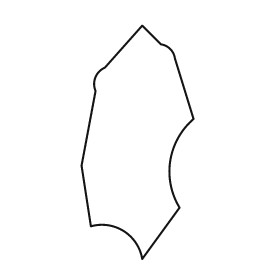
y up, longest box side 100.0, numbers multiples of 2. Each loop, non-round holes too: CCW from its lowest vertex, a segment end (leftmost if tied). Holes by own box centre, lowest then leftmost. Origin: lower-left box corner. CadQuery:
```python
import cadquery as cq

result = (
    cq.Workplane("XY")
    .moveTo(26.0, 0.0)
    .lineTo(42.0, 22.0)
    .threePointArc((38.0, 42.0), (48.0, 60.0))
    .lineTo(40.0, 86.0)
    .threePointArc((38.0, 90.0), (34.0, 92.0))
    .lineTo(26.0, 100.0)
    .lineTo(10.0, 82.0)
    .threePointArc((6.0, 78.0), (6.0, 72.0))
    .lineTo(0.0, 40.0)
    .lineTo(4.0, 14.0)
    .threePointArc((18.0, 12.0), (26.0, 0.0))
    .close()
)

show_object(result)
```